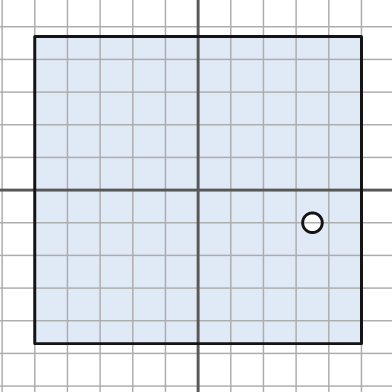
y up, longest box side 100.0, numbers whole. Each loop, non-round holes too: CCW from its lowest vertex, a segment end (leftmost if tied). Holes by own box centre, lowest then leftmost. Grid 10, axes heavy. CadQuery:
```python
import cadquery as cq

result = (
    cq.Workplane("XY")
    .moveTo(-50.0, -47.0)
    .lineTo(50.0, -47.0)
    .lineTo(50.0, 47.0)
    .lineTo(-50.0, 47.0)
    .close()
    .moveTo(35.0, -10.0)
    .circle(3.0)
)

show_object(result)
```